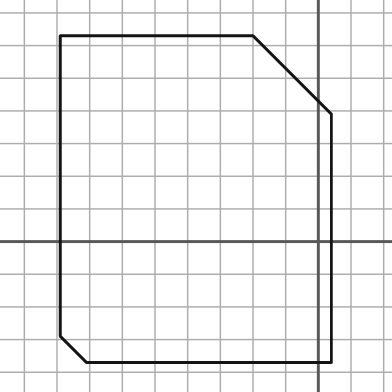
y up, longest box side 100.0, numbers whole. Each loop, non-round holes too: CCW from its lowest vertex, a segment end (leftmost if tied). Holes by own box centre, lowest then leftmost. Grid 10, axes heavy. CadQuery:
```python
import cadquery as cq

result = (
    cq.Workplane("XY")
    .moveTo(-71.0, -37.0)
    .lineTo(4.0, -37.0)
    .lineTo(4.0, 39.0)
    .lineTo(-20.0, 63.0)
    .lineTo(-79.0, 63.0)
    .lineTo(-79.0, -29.0)
    .close()
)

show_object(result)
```